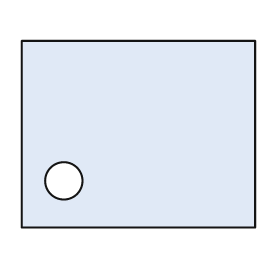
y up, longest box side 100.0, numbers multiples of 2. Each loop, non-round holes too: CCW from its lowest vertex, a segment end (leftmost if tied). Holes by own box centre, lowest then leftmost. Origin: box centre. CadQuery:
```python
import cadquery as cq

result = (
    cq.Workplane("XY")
    .moveTo(-50.0, -40.0)
    .lineTo(50.0, -40.0)
    .lineTo(50.0, 40.0)
    .lineTo(-50.0, 40.0)
    .close()
    .moveTo(-32.0, -20.0)
    .circle(8.0)
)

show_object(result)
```